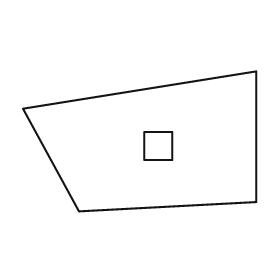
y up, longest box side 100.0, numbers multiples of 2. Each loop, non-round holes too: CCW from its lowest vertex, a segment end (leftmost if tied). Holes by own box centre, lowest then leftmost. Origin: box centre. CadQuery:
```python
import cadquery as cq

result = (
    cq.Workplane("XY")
    .moveTo(-26.0, -30.0)
    .lineTo(50.0, -26.0)
    .lineTo(50.0, 30.0)
    .lineTo(-50.0, 14.0)
    .close()
    .moveTo(2.0, -8.0)
    .lineTo(14.0, -8.0)
    .lineTo(14.0, 4.0)
    .lineTo(2.0, 4.0)
    .close()
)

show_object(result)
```